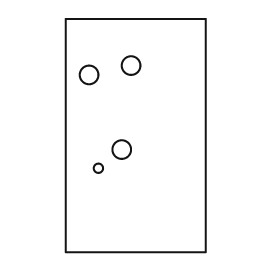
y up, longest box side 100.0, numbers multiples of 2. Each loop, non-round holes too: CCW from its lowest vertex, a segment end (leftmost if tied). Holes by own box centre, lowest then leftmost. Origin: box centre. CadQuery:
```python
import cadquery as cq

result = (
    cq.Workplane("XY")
    .moveTo(-30.0, -50.0)
    .lineTo(30.0, -50.0)
    .lineTo(30.0, 50.0)
    .lineTo(-30.0, 50.0)
    .close()
    .moveTo(-16.0, -14.0)
    .circle(2.0)
    .moveTo(-6.0, -6.0)
    .circle(4.0)
    .moveTo(-20.0, 26.0)
    .circle(4.0)
    .moveTo(-2.0, 30.0)
    .circle(4.0)
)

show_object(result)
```